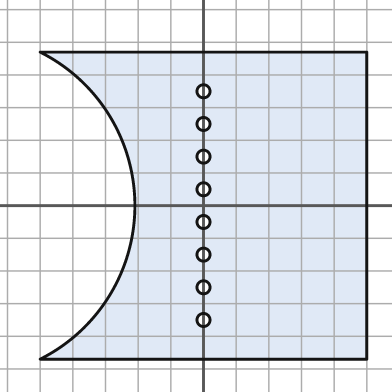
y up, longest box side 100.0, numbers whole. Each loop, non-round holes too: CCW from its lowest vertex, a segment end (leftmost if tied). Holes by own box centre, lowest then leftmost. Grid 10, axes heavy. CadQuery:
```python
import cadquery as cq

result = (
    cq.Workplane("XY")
    .moveTo(-50.0, -47.0)
    .lineTo(50.0, -47.0)
    .lineTo(50.0, 47.0)
    .lineTo(-50.0, 47.0)
    .threePointArc((-21.0, 0.0), (-50.0, -47.0))
    .close()
    .moveTo(0.0, -35.0)
    .circle(2.0)
    .moveTo(0.0, -25.0)
    .circle(2.0)
    .moveTo(0.0, -15.0)
    .circle(2.0)
    .moveTo(0.0, -5.0)
    .circle(2.0)
    .moveTo(0.0, 5.0)
    .circle(2.0)
    .moveTo(0.0, 15.0)
    .circle(2.0)
    .moveTo(0.0, 25.0)
    .circle(2.0)
    .moveTo(0.0, 35.0)
    .circle(2.0)
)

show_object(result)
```